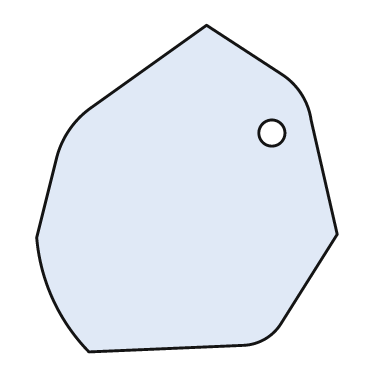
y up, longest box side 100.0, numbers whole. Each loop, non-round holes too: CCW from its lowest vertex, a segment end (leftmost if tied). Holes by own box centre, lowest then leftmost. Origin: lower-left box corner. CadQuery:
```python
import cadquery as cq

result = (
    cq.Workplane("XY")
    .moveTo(16.0, 0.0)
    .lineTo(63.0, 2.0)
    .threePointArc((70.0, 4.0), (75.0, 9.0))
    .lineTo(92.0, 36.0)
    .lineTo(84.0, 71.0)
    .threePointArc((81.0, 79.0), (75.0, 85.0))
    .lineTo(52.0, 100.0)
    .lineTo(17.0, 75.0)
    .threePointArc((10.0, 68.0), (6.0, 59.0))
    .lineTo(0.0, 35.0)
    .threePointArc((5.0, 16.0), (16.0, 0.0))
    .close()
    .moveTo(72.0, 67.0)
    .circle(4.0)
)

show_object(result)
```